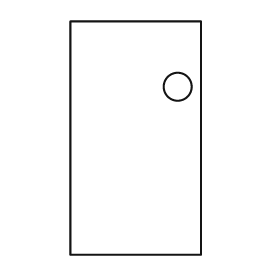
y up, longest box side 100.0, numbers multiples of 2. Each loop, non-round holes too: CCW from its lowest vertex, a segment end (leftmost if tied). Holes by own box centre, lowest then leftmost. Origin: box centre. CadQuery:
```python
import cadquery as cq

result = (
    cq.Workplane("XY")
    .moveTo(-28.0, -50.0)
    .lineTo(28.0, -50.0)
    .lineTo(28.0, 50.0)
    .lineTo(-28.0, 50.0)
    .close()
    .moveTo(18.0, 22.0)
    .circle(6.0)
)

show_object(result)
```